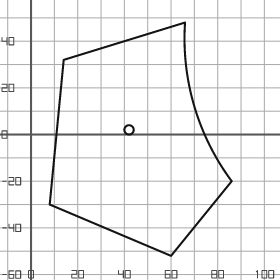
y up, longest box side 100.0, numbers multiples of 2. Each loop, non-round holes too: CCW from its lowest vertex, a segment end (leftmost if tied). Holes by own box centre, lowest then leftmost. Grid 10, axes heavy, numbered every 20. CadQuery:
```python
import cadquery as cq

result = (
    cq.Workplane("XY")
    .moveTo(60.0, -52.0)
    .lineTo(86.0, -20.0)
    .threePointArc((70.0, 12.0), (66.0, 48.0))
    .lineTo(14.0, 32.0)
    .lineTo(8.0, -30.0)
    .close()
    .moveTo(42.0, 2.0)
    .circle(2.0)
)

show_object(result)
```